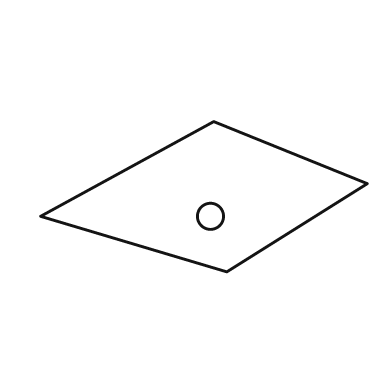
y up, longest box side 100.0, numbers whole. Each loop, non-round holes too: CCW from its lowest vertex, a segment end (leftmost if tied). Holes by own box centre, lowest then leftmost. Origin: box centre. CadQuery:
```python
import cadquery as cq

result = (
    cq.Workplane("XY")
    .moveTo(7.0, -23.0)
    .lineTo(50.0, 4.0)
    .lineTo(3.0, 23.0)
    .lineTo(-50.0, -6.0)
    .close()
    .moveTo(2.0, -6.0)
    .circle(4.0)
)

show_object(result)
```